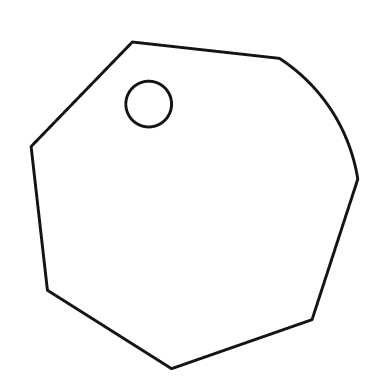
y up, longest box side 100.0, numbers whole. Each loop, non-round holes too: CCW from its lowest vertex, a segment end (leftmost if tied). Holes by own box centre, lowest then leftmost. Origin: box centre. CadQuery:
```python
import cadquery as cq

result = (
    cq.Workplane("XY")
    .moveTo(-7.0, -50.0)
    .lineTo(36.0, -35.0)
    .lineTo(50.0, 8.0)
    .threePointArc((42.0, 29.0), (26.0, 45.0))
    .lineTo(-19.0, 50.0)
    .lineTo(-50.0, 18.0)
    .lineTo(-45.0, -26.0)
    .close()
    .moveTo(-14.0, 31.0)
    .circle(7.0)
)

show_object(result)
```